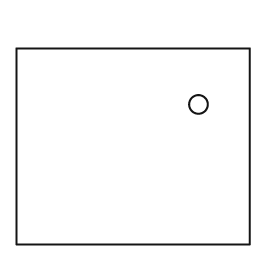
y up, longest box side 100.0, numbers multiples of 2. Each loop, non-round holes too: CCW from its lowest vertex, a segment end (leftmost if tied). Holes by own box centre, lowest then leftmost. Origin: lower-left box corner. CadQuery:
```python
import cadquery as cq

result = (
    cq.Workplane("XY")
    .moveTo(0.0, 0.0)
    .lineTo(100.0, 0.0)
    .lineTo(100.0, 84.0)
    .lineTo(0.0, 84.0)
    .close()
    .moveTo(78.0, 60.0)
    .circle(4.0)
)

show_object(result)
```